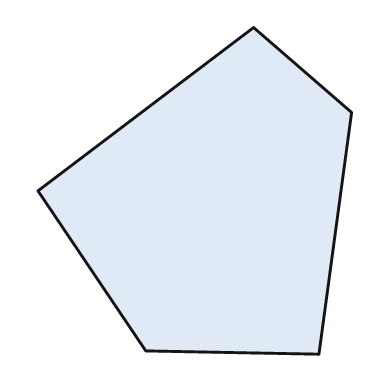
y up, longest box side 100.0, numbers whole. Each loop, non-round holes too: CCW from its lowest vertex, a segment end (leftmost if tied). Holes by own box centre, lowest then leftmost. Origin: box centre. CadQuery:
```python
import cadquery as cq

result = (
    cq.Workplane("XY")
    .moveTo(38.0, -50.0)
    .lineTo(48.0, 24.0)
    .lineTo(18.0, 50.0)
    .lineTo(-48.0, 0.0)
    .lineTo(-15.0, -49.0)
    .close()
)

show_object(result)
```